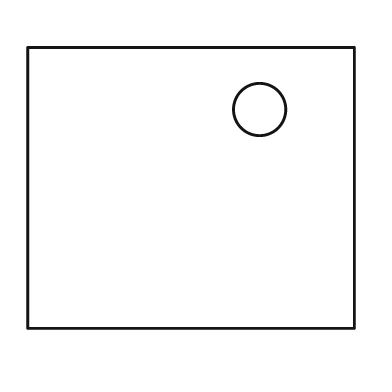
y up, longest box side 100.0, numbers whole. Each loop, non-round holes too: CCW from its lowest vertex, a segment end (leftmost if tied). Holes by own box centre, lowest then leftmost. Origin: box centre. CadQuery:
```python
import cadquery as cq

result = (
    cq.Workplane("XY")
    .moveTo(-50.0, -43.0)
    .lineTo(50.0, -43.0)
    .lineTo(50.0, 43.0)
    .lineTo(-50.0, 43.0)
    .close()
    .moveTo(21.0, 24.0)
    .circle(8.0)
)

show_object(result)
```